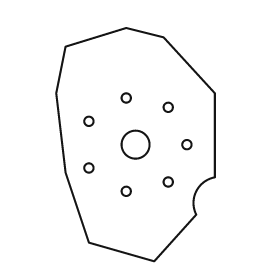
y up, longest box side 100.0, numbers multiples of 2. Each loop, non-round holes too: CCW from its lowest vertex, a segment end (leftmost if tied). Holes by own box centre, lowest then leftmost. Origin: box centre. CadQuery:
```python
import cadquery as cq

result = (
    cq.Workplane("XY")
    .moveTo(8.0, -50.0)
    .lineTo(26.0, -30.0)
    .threePointArc((26.0, -20.0), (34.0, -14.0))
    .lineTo(34.0, 22.0)
    .lineTo(12.0, 46.0)
    .lineTo(-4.0, 50.0)
    .lineTo(-30.0, 42.0)
    .lineTo(-34.0, 22.0)
    .lineTo(-30.0, -12.0)
    .lineTo(-20.0, -42.0)
    .close()
    .moveTo(-4.0, -20.0)
    .circle(2.0)
    .moveTo(14.0, -16.0)
    .circle(2.0)
    .moveTo(-20.0, -10.0)
    .circle(2.0)
    .moveTo(0.0, 0.0)
    .circle(6.0)
    .moveTo(22.0, 0.0)
    .circle(2.0)
    .moveTo(-20.0, 10.0)
    .circle(2.0)
    .moveTo(14.0, 16.0)
    .circle(2.0)
    .moveTo(-4.0, 20.0)
    .circle(2.0)
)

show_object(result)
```